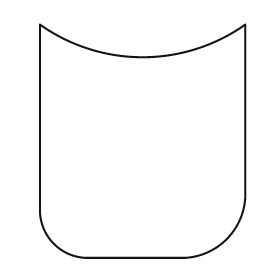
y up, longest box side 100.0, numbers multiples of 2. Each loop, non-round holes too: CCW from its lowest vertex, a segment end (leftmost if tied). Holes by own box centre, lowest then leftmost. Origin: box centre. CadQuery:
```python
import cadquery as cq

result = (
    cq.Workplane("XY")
    .moveTo(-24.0, -50.0)
    .lineTo(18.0, -50.0)
    .threePointArc((36.0, -42.0), (44.0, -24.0))
    .lineTo(44.0, 50.0)
    .threePointArc((0.0, 36.0), (-44.0, 50.0))
    .lineTo(-44.0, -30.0)
    .threePointArc((-38.0, -44.0), (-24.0, -50.0))
    .close()
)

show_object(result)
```